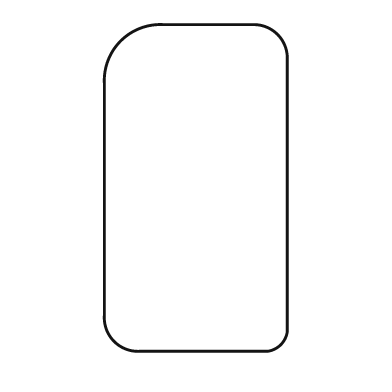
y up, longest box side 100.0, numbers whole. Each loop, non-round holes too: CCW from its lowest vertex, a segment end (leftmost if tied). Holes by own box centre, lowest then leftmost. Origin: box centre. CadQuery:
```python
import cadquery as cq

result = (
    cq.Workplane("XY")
    .moveTo(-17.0, -50.0)
    .lineTo(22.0, -50.0)
    .threePointArc((26.0, -48.0), (28.0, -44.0))
    .lineTo(28.0, 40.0)
    .threePointArc((25.0, 47.0), (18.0, 50.0))
    .lineTo(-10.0, 50.0)
    .threePointArc((-23.0, 45.0), (-28.0, 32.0))
    .lineTo(-28.0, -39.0)
    .threePointArc((-25.0, -47.0), (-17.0, -50.0))
    .close()
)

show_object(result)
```